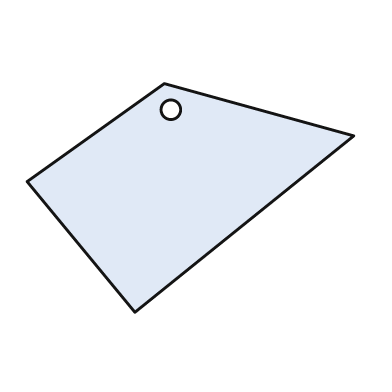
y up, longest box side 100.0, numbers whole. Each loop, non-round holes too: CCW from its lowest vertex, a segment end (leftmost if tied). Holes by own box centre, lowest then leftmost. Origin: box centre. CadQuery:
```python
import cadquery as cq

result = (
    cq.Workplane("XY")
    .moveTo(-17.0, -35.0)
    .lineTo(50.0, 19.0)
    .lineTo(-8.0, 35.0)
    .lineTo(-50.0, 5.0)
    .close()
    .moveTo(-6.0, 27.0)
    .circle(3.0)
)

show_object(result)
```